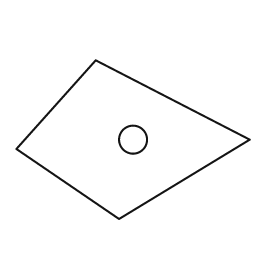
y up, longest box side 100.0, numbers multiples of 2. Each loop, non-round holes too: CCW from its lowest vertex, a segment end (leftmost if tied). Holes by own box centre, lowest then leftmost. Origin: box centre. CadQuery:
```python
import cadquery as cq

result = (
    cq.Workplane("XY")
    .moveTo(-6.0, -34.0)
    .lineTo(50.0, 0.0)
    .lineTo(-16.0, 34.0)
    .lineTo(-50.0, -4.0)
    .close()
    .moveTo(0.0, 0.0)
    .circle(6.0)
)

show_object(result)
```